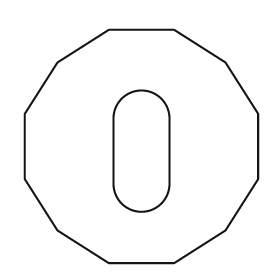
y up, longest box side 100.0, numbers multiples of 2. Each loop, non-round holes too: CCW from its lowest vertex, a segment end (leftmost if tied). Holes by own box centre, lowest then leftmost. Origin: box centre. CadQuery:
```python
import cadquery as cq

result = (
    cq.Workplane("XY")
    .moveTo(-14.0, -50.0)
    .lineTo(14.0, -50.0)
    .lineTo(36.0, -36.0)
    .lineTo(50.0, -14.0)
    .lineTo(50.0, 14.0)
    .lineTo(36.0, 36.0)
    .lineTo(14.0, 50.0)
    .lineTo(-14.0, 50.0)
    .lineTo(-36.0, 36.0)
    .lineTo(-50.0, 14.0)
    .lineTo(-50.0, -14.0)
    .lineTo(-36.0, -36.0)
    .close()
    .moveTo(-12.0, -16.0)
    .threePointArc((0.0, -28.0), (12.0, -16.0))
    .lineTo(12.0, 12.0)
    .threePointArc((0.0, 24.0), (-12.0, 12.0))
    .close()
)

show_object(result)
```